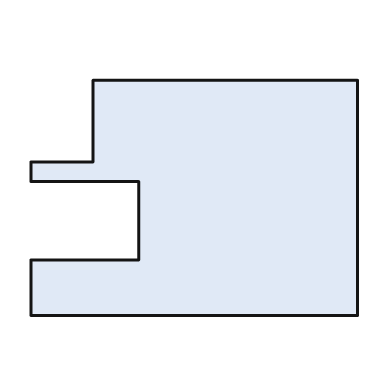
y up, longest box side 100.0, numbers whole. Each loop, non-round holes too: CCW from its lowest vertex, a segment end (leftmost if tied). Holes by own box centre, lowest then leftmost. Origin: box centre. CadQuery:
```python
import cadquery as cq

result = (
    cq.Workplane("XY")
    .moveTo(-50.0, -36.0)
    .lineTo(50.0, -36.0)
    .lineTo(50.0, 36.0)
    .lineTo(-31.0, 36.0)
    .lineTo(-31.0, 11.0)
    .lineTo(-50.0, 11.0)
    .lineTo(-50.0, 5.0)
    .lineTo(-17.0, 5.0)
    .lineTo(-17.0, -19.0)
    .lineTo(-50.0, -19.0)
    .close()
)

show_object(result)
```